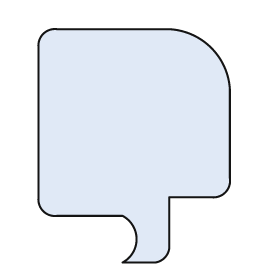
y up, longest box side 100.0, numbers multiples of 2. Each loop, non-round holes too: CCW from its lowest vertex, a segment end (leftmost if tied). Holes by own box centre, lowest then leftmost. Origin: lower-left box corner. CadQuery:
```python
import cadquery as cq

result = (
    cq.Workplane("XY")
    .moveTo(36.0, 0.0)
    .lineTo(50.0, 0.0)
    .threePointArc((54.0, 2.0), (56.0, 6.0))
    .lineTo(56.0, 28.0)
    .lineTo(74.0, 28.0)
    .threePointArc((80.0, 30.0), (82.0, 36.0))
    .lineTo(82.0, 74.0)
    .threePointArc((74.0, 92.0), (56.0, 100.0))
    .lineTo(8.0, 100.0)
    .threePointArc((2.0, 98.0), (0.0, 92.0))
    .lineTo(0.0, 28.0)
    .threePointArc((2.0, 22.0), (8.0, 20.0))
    .lineTo(36.0, 20.0)
    .threePointArc((42.0, 10.0), (36.0, 0.0))
    .close()
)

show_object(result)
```